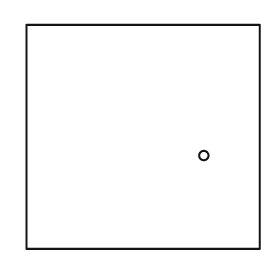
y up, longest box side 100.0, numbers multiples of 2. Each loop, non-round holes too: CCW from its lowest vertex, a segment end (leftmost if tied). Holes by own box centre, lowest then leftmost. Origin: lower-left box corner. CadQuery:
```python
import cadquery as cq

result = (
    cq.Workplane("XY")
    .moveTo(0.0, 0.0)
    .lineTo(100.0, 0.0)
    .lineTo(100.0, 96.0)
    .lineTo(0.0, 96.0)
    .close()
    .moveTo(76.0, 40.0)
    .circle(2.0)
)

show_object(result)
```